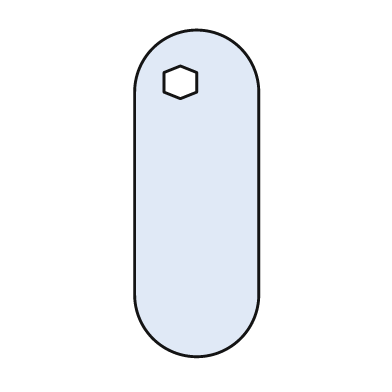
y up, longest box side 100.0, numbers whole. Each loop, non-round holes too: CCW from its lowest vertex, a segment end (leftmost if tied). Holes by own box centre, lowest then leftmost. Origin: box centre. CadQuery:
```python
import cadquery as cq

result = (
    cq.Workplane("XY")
    .moveTo(-19.0, -31.0)
    .threePointArc((0.0, -50.0), (19.0, -31.0))
    .lineTo(19.0, 31.0)
    .threePointArc((0.0, 50.0), (-19.0, 31.0))
    .close()
    .moveTo(-5.0, 29.0)
    .lineTo(0.0, 31.0)
    .lineTo(0.0, 37.0)
    .lineTo(-5.0, 39.0)
    .lineTo(-10.0, 37.0)
    .lineTo(-10.0, 31.0)
    .close()
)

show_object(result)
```